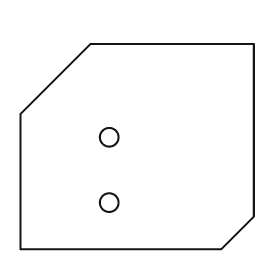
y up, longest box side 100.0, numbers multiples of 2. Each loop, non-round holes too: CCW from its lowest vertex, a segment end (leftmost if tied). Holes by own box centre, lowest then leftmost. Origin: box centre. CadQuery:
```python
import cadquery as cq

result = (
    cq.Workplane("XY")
    .moveTo(-50.0, -44.0)
    .lineTo(36.0, -44.0)
    .lineTo(50.0, -30.0)
    .lineTo(50.0, 44.0)
    .lineTo(-20.0, 44.0)
    .lineTo(-50.0, 14.0)
    .close()
    .moveTo(-12.0, -24.0)
    .circle(4.0)
    .moveTo(-12.0, 4.0)
    .circle(4.0)
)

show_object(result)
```